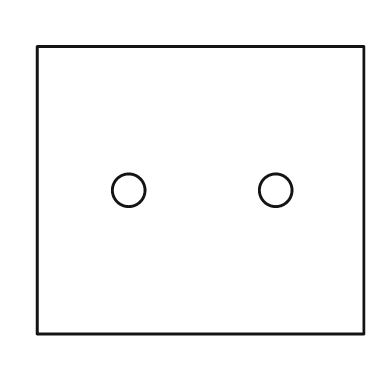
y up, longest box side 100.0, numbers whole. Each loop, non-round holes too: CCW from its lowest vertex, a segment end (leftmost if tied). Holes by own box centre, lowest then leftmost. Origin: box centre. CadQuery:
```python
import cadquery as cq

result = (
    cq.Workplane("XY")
    .moveTo(-50.0, -44.0)
    .lineTo(50.0, -44.0)
    .lineTo(50.0, 44.0)
    .lineTo(-50.0, 44.0)
    .close()
    .moveTo(-22.0, 0.0)
    .circle(5.0)
    .moveTo(23.0, 0.0)
    .circle(5.0)
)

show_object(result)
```